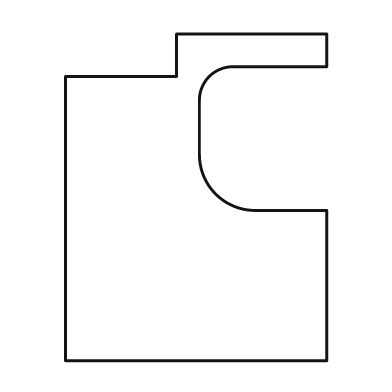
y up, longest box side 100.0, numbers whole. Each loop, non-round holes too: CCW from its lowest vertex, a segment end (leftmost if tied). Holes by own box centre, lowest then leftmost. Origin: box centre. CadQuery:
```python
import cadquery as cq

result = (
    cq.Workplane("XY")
    .moveTo(-40.0, -50.0)
    .lineTo(40.0, -50.0)
    .lineTo(40.0, -4.0)
    .lineTo(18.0, -4.0)
    .threePointArc((6.0, 1.0), (1.0, 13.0))
    .lineTo(1.0, 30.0)
    .threePointArc((4.0, 37.0), (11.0, 40.0))
    .lineTo(40.0, 40.0)
    .lineTo(40.0, 50.0)
    .lineTo(-6.0, 50.0)
    .lineTo(-6.0, 37.0)
    .lineTo(-40.0, 37.0)
    .close()
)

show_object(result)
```